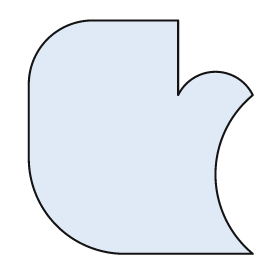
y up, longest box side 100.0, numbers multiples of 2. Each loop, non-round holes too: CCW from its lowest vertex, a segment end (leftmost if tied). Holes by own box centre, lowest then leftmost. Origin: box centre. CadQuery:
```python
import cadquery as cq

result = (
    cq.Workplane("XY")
    .moveTo(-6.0, -50.0)
    .lineTo(48.0, -50.0)
    .threePointArc((32.0, -16.0), (48.0, 18.0))
    .threePointArc((32.0, 28.0), (16.0, 18.0))
    .lineTo(16.0, 50.0)
    .lineTo(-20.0, 50.0)
    .threePointArc((-40.0, 42.0), (-48.0, 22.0))
    .lineTo(-48.0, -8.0)
    .threePointArc((-36.0, -38.0), (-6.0, -50.0))
    .close()
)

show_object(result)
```